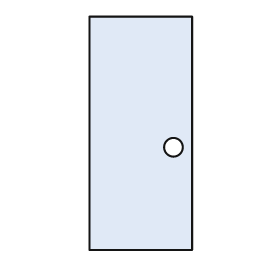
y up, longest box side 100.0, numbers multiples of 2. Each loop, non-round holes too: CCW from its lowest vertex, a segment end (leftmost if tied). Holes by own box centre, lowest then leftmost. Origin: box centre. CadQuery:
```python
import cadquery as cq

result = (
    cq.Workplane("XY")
    .moveTo(-22.0, -50.0)
    .lineTo(22.0, -50.0)
    .lineTo(22.0, 50.0)
    .lineTo(-22.0, 50.0)
    .close()
    .moveTo(14.0, -6.0)
    .circle(4.0)
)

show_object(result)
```